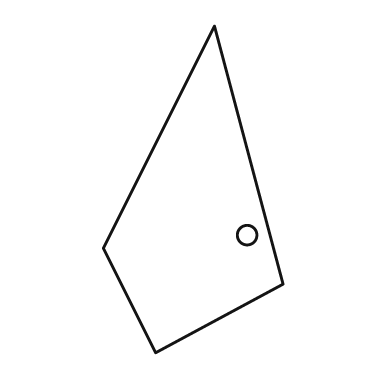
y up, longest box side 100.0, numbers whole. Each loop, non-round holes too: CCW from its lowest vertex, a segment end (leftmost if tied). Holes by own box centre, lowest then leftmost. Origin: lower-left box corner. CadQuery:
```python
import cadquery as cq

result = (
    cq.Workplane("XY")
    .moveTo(16.0, 0.0)
    .lineTo(55.0, 21.0)
    .lineTo(34.0, 100.0)
    .lineTo(0.0, 32.0)
    .close()
    .moveTo(44.0, 36.0)
    .circle(3.0)
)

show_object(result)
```